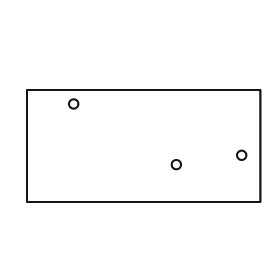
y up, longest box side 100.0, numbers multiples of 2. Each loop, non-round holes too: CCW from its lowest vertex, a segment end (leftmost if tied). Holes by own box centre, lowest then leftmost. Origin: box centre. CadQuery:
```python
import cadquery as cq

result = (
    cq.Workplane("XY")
    .moveTo(-50.0, -24.0)
    .lineTo(50.0, -24.0)
    .lineTo(50.0, 24.0)
    .lineTo(-50.0, 24.0)
    .close()
    .moveTo(14.0, -8.0)
    .circle(2.0)
    .moveTo(42.0, -4.0)
    .circle(2.0)
    .moveTo(-30.0, 18.0)
    .circle(2.0)
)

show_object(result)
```